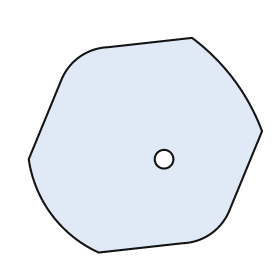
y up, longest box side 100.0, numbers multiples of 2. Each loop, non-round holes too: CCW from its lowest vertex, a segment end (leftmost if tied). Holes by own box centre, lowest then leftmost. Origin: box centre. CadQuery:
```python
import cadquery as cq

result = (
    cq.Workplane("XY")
    .moveTo(-20.0, -46.0)
    .lineTo(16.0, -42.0)
    .threePointArc((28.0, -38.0), (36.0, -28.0))
    .lineTo(50.0, 6.0)
    .threePointArc((38.0, 28.0), (20.0, 46.0))
    .lineTo(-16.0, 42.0)
    .threePointArc((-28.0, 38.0), (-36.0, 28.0))
    .lineTo(-50.0, -6.0)
    .threePointArc((-40.0, -30.0), (-20.0, -46.0))
    .close()
    .moveTo(8.0, -6.0)
    .circle(4.0)
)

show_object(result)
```